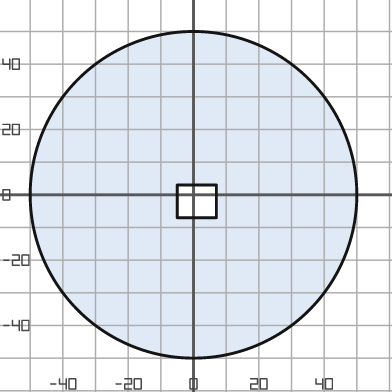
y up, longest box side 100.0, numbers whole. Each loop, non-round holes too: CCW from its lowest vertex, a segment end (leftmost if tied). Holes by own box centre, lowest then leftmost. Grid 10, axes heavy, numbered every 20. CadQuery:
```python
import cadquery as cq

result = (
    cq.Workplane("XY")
    .moveTo(0.0, 0.0)
    .circle(50.0)
    .moveTo(-5.0, -7.0)
    .lineTo(7.0, -7.0)
    .lineTo(7.0, 3.0)
    .lineTo(-5.0, 3.0)
    .close()
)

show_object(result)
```